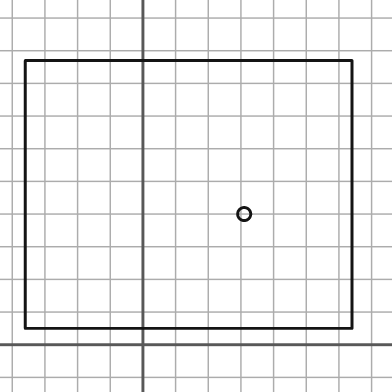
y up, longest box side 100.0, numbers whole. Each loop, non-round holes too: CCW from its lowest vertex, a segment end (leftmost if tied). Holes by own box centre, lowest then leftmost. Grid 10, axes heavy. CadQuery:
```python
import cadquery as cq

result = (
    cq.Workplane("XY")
    .moveTo(-36.0, 5.0)
    .lineTo(64.0, 5.0)
    .lineTo(64.0, 87.0)
    .lineTo(-36.0, 87.0)
    .close()
    .moveTo(31.0, 40.0)
    .circle(2.0)
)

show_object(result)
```